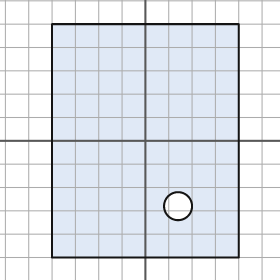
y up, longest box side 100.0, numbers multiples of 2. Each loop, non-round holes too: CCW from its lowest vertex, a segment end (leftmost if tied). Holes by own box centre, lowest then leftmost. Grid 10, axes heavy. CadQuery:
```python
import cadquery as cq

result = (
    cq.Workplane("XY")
    .moveTo(-40.0, -50.0)
    .lineTo(40.0, -50.0)
    .lineTo(40.0, 50.0)
    .lineTo(-40.0, 50.0)
    .close()
    .moveTo(14.0, -28.0)
    .circle(6.0)
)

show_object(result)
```